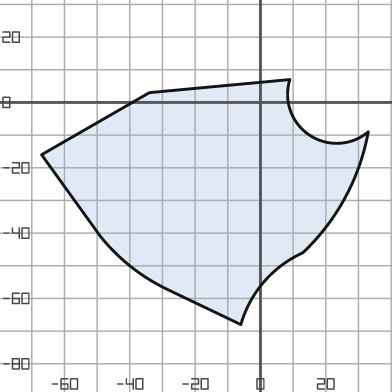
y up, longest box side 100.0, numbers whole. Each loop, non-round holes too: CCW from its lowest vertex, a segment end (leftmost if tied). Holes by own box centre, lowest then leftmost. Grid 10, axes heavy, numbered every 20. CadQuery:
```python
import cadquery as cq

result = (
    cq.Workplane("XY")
    .moveTo(-6.0, -68.0)
    .threePointArc((1.0, -55.0), (13.0, -46.0))
    .threePointArc((26.0, -29.0), (33.0, -9.0))
    .threePointArc((15.0, -10.0), (9.0, 7.0))
    .lineTo(-34.0, 3.0)
    .lineTo(-67.0, -16.0)
    .lineTo(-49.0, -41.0)
    .threePointArc((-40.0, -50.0), (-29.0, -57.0))
    .close()
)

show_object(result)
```